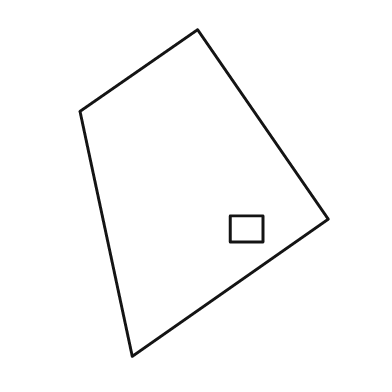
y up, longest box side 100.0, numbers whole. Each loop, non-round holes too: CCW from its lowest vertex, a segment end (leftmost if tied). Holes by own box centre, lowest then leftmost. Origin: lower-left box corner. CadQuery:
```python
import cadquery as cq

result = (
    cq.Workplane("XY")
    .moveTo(16.0, 0.0)
    .lineTo(76.0, 42.0)
    .lineTo(36.0, 100.0)
    .lineTo(0.0, 75.0)
    .close()
    .moveTo(46.0, 35.0)
    .lineTo(56.0, 35.0)
    .lineTo(56.0, 43.0)
    .lineTo(46.0, 43.0)
    .close()
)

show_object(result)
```